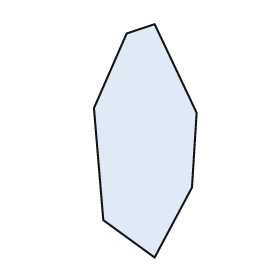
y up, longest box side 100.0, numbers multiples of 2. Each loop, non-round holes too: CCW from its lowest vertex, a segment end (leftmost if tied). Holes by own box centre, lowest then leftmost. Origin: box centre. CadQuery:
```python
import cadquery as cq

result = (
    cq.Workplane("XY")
    .moveTo(4.0, -50.0)
    .lineTo(20.0, -20.0)
    .lineTo(22.0, 12.0)
    .lineTo(4.0, 50.0)
    .lineTo(-8.0, 46.0)
    .lineTo(-22.0, 14.0)
    .lineTo(-18.0, -34.0)
    .close()
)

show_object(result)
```